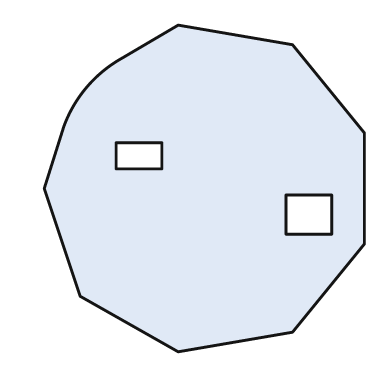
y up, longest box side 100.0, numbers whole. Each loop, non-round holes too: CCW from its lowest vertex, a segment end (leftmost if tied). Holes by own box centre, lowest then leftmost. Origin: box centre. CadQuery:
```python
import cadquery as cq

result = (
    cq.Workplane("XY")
    .moveTo(-8.0, -50.0)
    .lineTo(27.0, -44.0)
    .lineTo(49.0, -17.0)
    .lineTo(49.0, 17.0)
    .lineTo(27.0, 44.0)
    .lineTo(-8.0, 50.0)
    .lineTo(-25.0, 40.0)
    .threePointArc((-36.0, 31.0), (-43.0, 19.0))
    .lineTo(-49.0, 0.0)
    .lineTo(-38.0, -33.0)
    .close()
    .moveTo(25.0, -14.0)
    .lineTo(39.0, -14.0)
    .lineTo(39.0, -2.0)
    .lineTo(25.0, -2.0)
    .close()
    .moveTo(-27.0, 6.0)
    .lineTo(-13.0, 6.0)
    .lineTo(-13.0, 14.0)
    .lineTo(-27.0, 14.0)
    .close()
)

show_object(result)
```